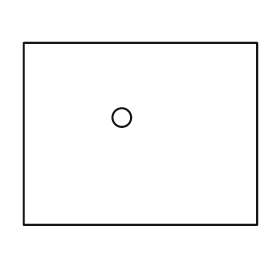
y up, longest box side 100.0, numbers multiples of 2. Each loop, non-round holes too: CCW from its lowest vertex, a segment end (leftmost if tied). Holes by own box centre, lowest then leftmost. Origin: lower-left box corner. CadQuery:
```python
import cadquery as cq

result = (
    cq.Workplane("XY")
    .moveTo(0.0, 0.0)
    .lineTo(100.0, 0.0)
    .lineTo(100.0, 78.0)
    .lineTo(0.0, 78.0)
    .close()
    .moveTo(42.0, 46.0)
    .circle(4.0)
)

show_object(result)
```